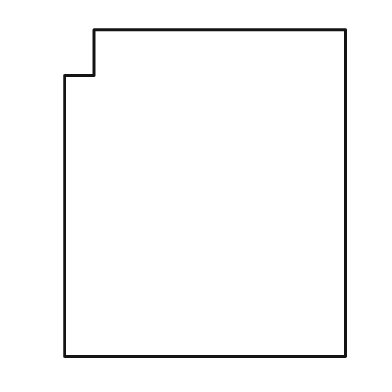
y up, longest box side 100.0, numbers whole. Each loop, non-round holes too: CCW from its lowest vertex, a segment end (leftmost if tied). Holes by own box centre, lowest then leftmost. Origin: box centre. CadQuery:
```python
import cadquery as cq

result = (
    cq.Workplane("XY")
    .moveTo(-43.0, -50.0)
    .lineTo(43.0, -50.0)
    .lineTo(43.0, 50.0)
    .lineTo(-34.0, 50.0)
    .lineTo(-34.0, 36.0)
    .lineTo(-43.0, 36.0)
    .close()
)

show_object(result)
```